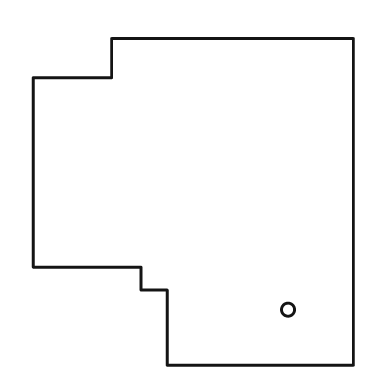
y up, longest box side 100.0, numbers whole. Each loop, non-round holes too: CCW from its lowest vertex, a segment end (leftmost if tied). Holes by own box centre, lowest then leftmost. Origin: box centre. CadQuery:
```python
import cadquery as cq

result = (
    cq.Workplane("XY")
    .moveTo(-8.0, -50.0)
    .lineTo(49.0, -50.0)
    .lineTo(49.0, 50.0)
    .lineTo(-25.0, 50.0)
    .lineTo(-25.0, 38.0)
    .lineTo(-49.0, 38.0)
    .lineTo(-49.0, -20.0)
    .lineTo(-16.0, -20.0)
    .lineTo(-16.0, -27.0)
    .lineTo(-8.0, -27.0)
    .close()
    .moveTo(29.0, -33.0)
    .circle(2.0)
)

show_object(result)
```